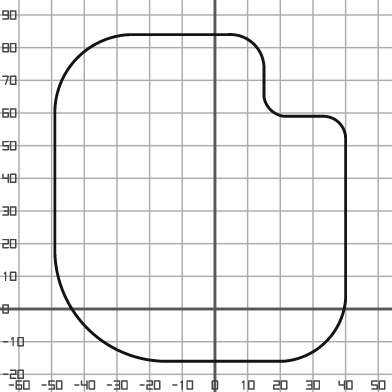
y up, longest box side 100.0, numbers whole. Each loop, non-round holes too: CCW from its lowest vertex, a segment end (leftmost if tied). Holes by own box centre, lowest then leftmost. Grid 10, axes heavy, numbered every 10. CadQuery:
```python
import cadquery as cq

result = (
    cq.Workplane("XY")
    .moveTo(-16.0, -16.0)
    .lineTo(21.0, -16.0)
    .threePointArc((34.0, -10.0), (40.0, 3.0))
    .lineTo(40.0, 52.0)
    .threePointArc((38.0, 57.0), (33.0, 59.0))
    .lineTo(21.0, 59.0)
    .threePointArc((17.0, 61.0), (15.0, 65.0))
    .lineTo(15.0, 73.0)
    .threePointArc((12.0, 81.0), (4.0, 84.0))
    .lineTo(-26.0, 84.0)
    .threePointArc((-42.0, 77.0), (-49.0, 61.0))
    .lineTo(-49.0, 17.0)
    .threePointArc((-39.0, -6.0), (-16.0, -16.0))
    .close()
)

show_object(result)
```